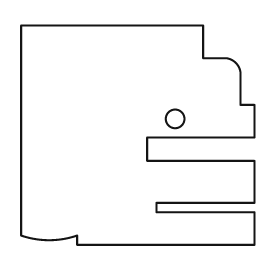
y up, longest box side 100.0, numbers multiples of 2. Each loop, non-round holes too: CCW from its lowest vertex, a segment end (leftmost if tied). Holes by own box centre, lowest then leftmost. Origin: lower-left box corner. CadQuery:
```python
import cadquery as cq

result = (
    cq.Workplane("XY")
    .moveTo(24.0, 0.0)
    .lineTo(100.0, 0.0)
    .lineTo(100.0, 14.0)
    .lineTo(58.0, 14.0)
    .lineTo(58.0, 18.0)
    .lineTo(100.0, 18.0)
    .lineTo(100.0, 36.0)
    .lineTo(54.0, 36.0)
    .lineTo(54.0, 46.0)
    .lineTo(100.0, 46.0)
    .lineTo(100.0, 60.0)
    .lineTo(94.0, 60.0)
    .lineTo(94.0, 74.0)
    .threePointArc((92.0, 78.0), (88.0, 80.0))
    .lineTo(78.0, 80.0)
    .lineTo(78.0, 94.0)
    .lineTo(0.0, 94.0)
    .lineTo(0.0, 4.0)
    .threePointArc((12.0, 2.0), (24.0, 4.0))
    .close()
    .moveTo(66.0, 54.0)
    .circle(4.0)
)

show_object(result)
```